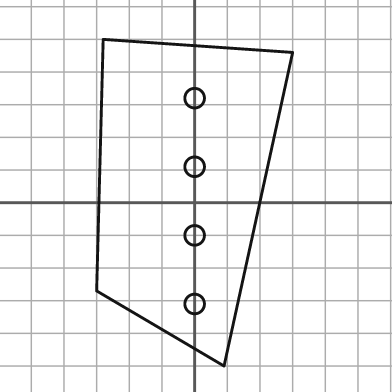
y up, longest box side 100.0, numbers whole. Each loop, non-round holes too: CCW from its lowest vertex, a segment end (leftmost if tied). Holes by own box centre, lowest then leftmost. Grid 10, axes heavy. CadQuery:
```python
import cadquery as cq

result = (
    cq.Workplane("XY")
    .moveTo(9.0, -50.0)
    .lineTo(30.0, 46.0)
    .lineTo(-28.0, 50.0)
    .lineTo(-30.0, -27.0)
    .close()
    .moveTo(0.0, -31.0)
    .circle(3.0)
    .moveTo(0.0, -10.0)
    .circle(3.0)
    .moveTo(0.0, 11.0)
    .circle(3.0)
    .moveTo(0.0, 32.0)
    .circle(3.0)
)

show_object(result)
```